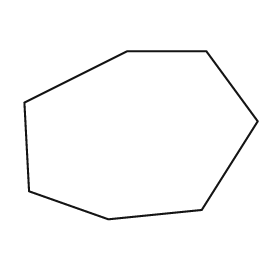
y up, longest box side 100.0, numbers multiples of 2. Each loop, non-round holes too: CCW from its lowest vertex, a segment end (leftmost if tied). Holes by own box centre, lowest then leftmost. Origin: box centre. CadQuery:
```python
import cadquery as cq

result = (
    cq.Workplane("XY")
    .moveTo(-14.0, -36.0)
    .lineTo(26.0, -32.0)
    .lineTo(50.0, 6.0)
    .lineTo(28.0, 36.0)
    .lineTo(-6.0, 36.0)
    .lineTo(-50.0, 14.0)
    .lineTo(-48.0, -24.0)
    .close()
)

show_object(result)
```